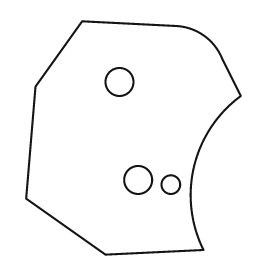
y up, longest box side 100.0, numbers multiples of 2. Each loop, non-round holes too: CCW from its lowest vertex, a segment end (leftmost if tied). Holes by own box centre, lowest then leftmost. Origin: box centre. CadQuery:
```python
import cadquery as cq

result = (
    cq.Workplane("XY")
    .moveTo(-12.0, -50.0)
    .lineTo(30.0, -48.0)
    .threePointArc((26.0, -12.0), (46.0, 18.0))
    .lineTo(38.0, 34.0)
    .threePointArc((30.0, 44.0), (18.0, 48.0))
    .lineTo(-22.0, 50.0)
    .lineTo(-42.0, 22.0)
    .lineTo(-46.0, -26.0)
    .close()
    .moveTo(16.0, -20.0)
    .circle(4.0)
    .moveTo(2.0, -18.0)
    .circle(6.0)
    .moveTo(-6.0, 24.0)
    .circle(6.0)
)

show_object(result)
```